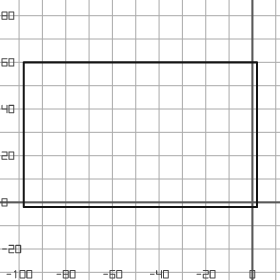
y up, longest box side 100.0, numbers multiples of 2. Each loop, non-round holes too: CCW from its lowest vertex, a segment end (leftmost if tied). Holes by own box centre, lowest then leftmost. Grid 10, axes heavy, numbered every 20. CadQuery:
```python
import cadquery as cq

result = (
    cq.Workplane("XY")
    .moveTo(-98.0, -2.0)
    .lineTo(2.0, -2.0)
    .lineTo(2.0, 60.0)
    .lineTo(-98.0, 60.0)
    .close()
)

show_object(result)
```